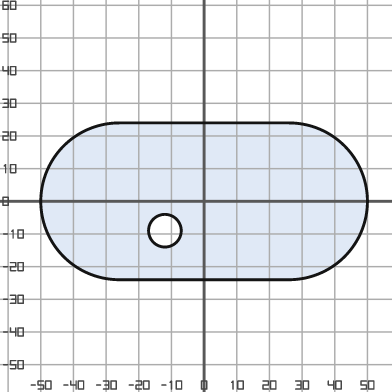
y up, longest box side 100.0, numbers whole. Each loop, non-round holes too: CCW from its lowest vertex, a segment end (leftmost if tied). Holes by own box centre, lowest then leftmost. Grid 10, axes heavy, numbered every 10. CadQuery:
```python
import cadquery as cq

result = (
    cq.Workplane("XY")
    .moveTo(-26.0, -24.0)
    .lineTo(26.0, -24.0)
    .threePointArc((50.0, 0.0), (26.0, 24.0))
    .lineTo(-26.0, 24.0)
    .threePointArc((-50.0, 0.0), (-26.0, -24.0))
    .close()
    .moveTo(-12.0, -9.0)
    .circle(5.0)
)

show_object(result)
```